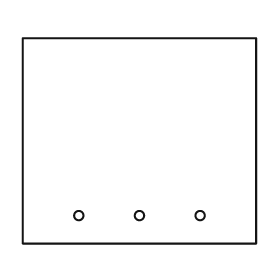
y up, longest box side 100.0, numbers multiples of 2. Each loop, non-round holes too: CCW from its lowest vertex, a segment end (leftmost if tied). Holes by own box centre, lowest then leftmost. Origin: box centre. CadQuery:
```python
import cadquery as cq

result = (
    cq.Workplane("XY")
    .moveTo(-50.0, -44.0)
    .lineTo(50.0, -44.0)
    .lineTo(50.0, 44.0)
    .lineTo(-50.0, 44.0)
    .close()
    .moveTo(-26.0, -32.0)
    .circle(2.0)
    .moveTo(0.0, -32.0)
    .circle(2.0)
    .moveTo(26.0, -32.0)
    .circle(2.0)
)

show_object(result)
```